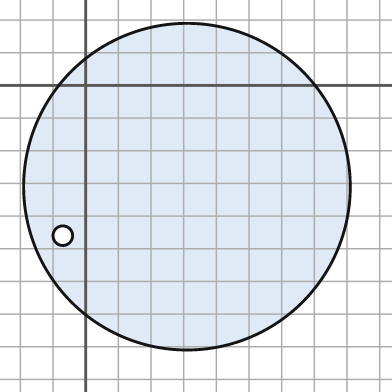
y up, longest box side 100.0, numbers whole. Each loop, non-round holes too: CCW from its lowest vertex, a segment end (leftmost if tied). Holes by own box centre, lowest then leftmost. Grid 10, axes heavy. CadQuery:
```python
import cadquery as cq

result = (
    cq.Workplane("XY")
    .moveTo(31.0, -31.0)
    .circle(50.0)
    .moveTo(-7.0, -46.0)
    .circle(3.0)
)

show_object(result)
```